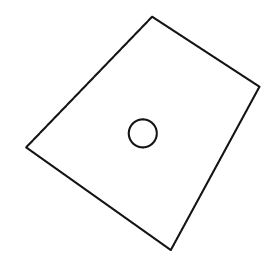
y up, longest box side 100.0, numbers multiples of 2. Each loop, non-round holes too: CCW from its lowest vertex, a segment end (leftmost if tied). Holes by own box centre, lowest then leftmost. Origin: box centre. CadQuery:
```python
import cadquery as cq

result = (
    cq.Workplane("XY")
    .moveTo(12.0, -50.0)
    .lineTo(50.0, 20.0)
    .lineTo(4.0, 50.0)
    .lineTo(-50.0, -6.0)
    .close()
    .moveTo(0.0, 0.0)
    .circle(6.0)
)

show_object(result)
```